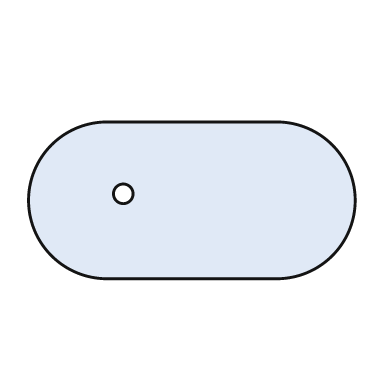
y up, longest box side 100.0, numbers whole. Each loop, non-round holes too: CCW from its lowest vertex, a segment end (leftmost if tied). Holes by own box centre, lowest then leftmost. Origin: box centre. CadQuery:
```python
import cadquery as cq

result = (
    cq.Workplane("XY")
    .moveTo(-26.0, -24.0)
    .lineTo(26.0, -24.0)
    .threePointArc((50.0, 0.0), (26.0, 24.0))
    .lineTo(-26.0, 24.0)
    .threePointArc((-50.0, 0.0), (-26.0, -24.0))
    .close()
    .moveTo(-21.0, 2.0)
    .circle(3.0)
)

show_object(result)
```